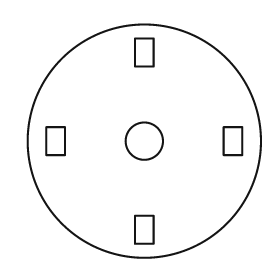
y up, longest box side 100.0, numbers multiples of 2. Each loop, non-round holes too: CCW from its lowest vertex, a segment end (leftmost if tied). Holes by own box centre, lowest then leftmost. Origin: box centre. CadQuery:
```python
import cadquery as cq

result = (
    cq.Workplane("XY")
    .moveTo(0.0, 0.0)
    .circle(50.0)
    .moveTo(-4.0, -44.0)
    .lineTo(4.0, -44.0)
    .lineTo(4.0, -32.0)
    .lineTo(-4.0, -32.0)
    .close()
    .moveTo(-42.0, -6.0)
    .lineTo(-34.0, -6.0)
    .lineTo(-34.0, 6.0)
    .lineTo(-42.0, 6.0)
    .close()
    .moveTo(0.0, 0.0)
    .circle(8.0)
    .moveTo(34.0, -6.0)
    .lineTo(42.0, -6.0)
    .lineTo(42.0, 6.0)
    .lineTo(34.0, 6.0)
    .close()
    .moveTo(-4.0, 32.0)
    .lineTo(4.0, 32.0)
    .lineTo(4.0, 44.0)
    .lineTo(-4.0, 44.0)
    .close()
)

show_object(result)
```